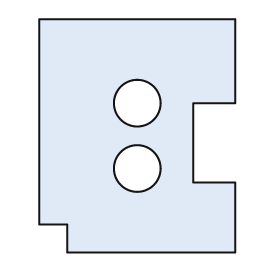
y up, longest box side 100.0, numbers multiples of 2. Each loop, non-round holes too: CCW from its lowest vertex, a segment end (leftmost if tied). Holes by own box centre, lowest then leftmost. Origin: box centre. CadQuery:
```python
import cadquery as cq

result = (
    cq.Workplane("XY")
    .moveTo(-30.0, -50.0)
    .lineTo(42.0, -50.0)
    .lineTo(42.0, -20.0)
    .lineTo(24.0, -20.0)
    .lineTo(24.0, 14.0)
    .lineTo(42.0, 14.0)
    .lineTo(42.0, 50.0)
    .lineTo(-42.0, 50.0)
    .lineTo(-42.0, -38.0)
    .lineTo(-30.0, -38.0)
    .close()
    .moveTo(0.0, -14.0)
    .circle(10.0)
    .moveTo(0.0, 14.0)
    .circle(10.0)
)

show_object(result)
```